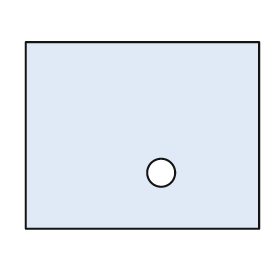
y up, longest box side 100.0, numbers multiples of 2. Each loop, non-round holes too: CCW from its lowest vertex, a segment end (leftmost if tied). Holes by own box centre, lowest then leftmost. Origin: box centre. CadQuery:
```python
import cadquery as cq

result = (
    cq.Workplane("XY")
    .moveTo(-50.0, -40.0)
    .lineTo(50.0, -40.0)
    .lineTo(50.0, 40.0)
    .lineTo(-50.0, 40.0)
    .close()
    .moveTo(8.0, -16.0)
    .circle(6.0)
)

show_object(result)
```